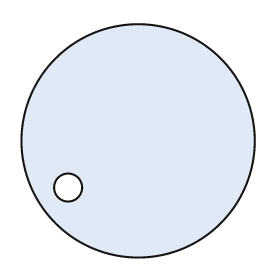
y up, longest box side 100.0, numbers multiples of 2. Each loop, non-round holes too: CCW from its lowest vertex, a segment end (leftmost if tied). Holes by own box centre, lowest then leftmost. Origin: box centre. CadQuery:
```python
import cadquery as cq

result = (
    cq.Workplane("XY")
    .moveTo(0.0, 0.0)
    .circle(50.0)
    .moveTo(-30.0, -20.0)
    .circle(6.0)
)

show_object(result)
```